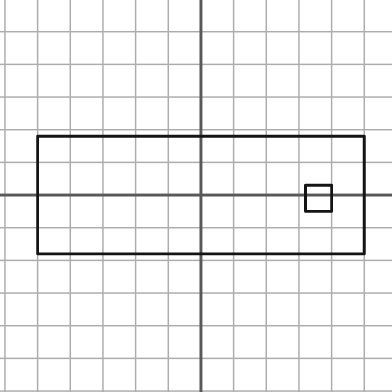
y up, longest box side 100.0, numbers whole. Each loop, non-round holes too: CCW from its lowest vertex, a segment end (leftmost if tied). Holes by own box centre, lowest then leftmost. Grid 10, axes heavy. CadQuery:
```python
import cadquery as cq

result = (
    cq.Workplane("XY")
    .moveTo(-50.0, -18.0)
    .lineTo(50.0, -18.0)
    .lineTo(50.0, 18.0)
    .lineTo(-50.0, 18.0)
    .close()
    .moveTo(32.0, -5.0)
    .lineTo(40.0, -5.0)
    .lineTo(40.0, 3.0)
    .lineTo(32.0, 3.0)
    .close()
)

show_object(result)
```